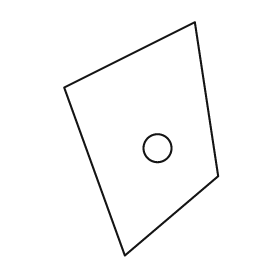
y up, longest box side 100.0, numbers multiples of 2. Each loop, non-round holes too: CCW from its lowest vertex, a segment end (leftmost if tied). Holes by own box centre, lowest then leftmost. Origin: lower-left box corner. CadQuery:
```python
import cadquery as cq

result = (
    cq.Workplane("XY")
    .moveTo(26.0, 0.0)
    .lineTo(66.0, 34.0)
    .lineTo(56.0, 100.0)
    .lineTo(0.0, 72.0)
    .close()
    .moveTo(40.0, 46.0)
    .circle(6.0)
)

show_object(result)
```